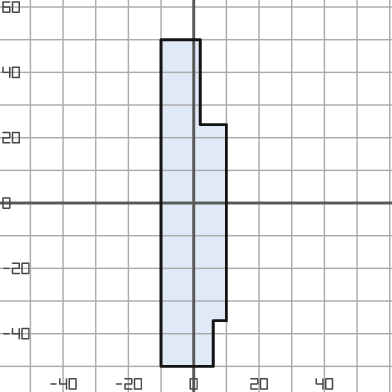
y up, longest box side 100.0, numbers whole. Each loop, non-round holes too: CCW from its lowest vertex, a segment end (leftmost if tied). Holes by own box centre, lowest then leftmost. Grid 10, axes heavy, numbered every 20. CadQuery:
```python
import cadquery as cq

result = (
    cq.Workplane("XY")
    .moveTo(-10.0, -50.0)
    .lineTo(6.0, -50.0)
    .lineTo(6.0, -36.0)
    .lineTo(10.0, -36.0)
    .lineTo(10.0, 24.0)
    .lineTo(2.0, 24.0)
    .lineTo(2.0, 50.0)
    .lineTo(-10.0, 50.0)
    .close()
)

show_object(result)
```